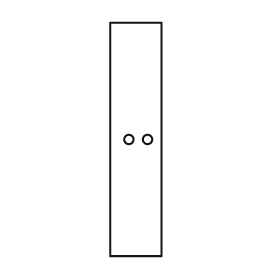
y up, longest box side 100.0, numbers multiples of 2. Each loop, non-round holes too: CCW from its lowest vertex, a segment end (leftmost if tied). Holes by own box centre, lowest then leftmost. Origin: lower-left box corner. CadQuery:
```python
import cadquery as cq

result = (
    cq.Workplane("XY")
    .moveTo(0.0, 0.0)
    .lineTo(22.0, 0.0)
    .lineTo(22.0, 100.0)
    .lineTo(0.0, 100.0)
    .close()
    .moveTo(8.0, 50.0)
    .circle(2.0)
    .moveTo(16.0, 50.0)
    .circle(2.0)
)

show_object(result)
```